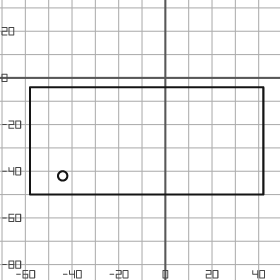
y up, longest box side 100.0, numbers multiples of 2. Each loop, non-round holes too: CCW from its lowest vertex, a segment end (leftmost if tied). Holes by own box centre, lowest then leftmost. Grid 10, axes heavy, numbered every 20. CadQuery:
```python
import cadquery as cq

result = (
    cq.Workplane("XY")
    .moveTo(-58.0, -50.0)
    .lineTo(42.0, -50.0)
    .lineTo(42.0, -4.0)
    .lineTo(-58.0, -4.0)
    .close()
    .moveTo(-44.0, -42.0)
    .circle(2.0)
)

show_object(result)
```